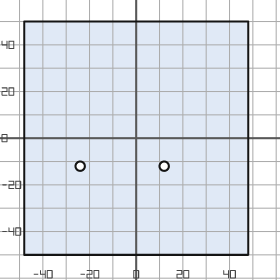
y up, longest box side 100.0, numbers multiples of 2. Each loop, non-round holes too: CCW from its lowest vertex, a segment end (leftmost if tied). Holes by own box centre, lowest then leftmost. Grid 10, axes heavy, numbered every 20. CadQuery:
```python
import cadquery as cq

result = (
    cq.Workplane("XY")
    .moveTo(-48.0, -50.0)
    .lineTo(48.0, -50.0)
    .lineTo(48.0, 50.0)
    .lineTo(-48.0, 50.0)
    .close()
    .moveTo(-24.0, -12.0)
    .circle(2.0)
    .moveTo(12.0, -12.0)
    .circle(2.0)
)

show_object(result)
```